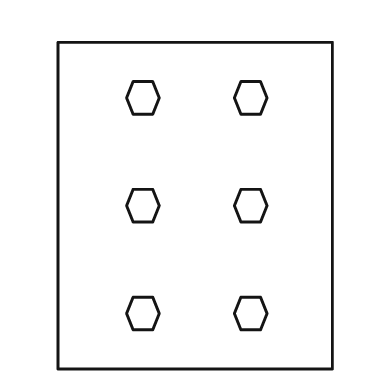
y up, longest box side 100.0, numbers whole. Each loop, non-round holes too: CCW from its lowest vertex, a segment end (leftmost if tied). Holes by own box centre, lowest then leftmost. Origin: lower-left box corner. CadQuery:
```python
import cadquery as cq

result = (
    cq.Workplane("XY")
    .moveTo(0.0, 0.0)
    .lineTo(84.0, 0.0)
    .lineTo(84.0, 100.0)
    .lineTo(0.0, 100.0)
    .close()
    .moveTo(23.0, 12.0)
    .lineTo(29.0, 12.0)
    .lineTo(31.0, 17.0)
    .lineTo(29.0, 22.0)
    .lineTo(23.0, 22.0)
    .lineTo(21.0, 17.0)
    .close()
    .moveTo(56.0, 12.0)
    .lineTo(62.0, 12.0)
    .lineTo(64.0, 17.0)
    .lineTo(62.0, 22.0)
    .lineTo(56.0, 22.0)
    .lineTo(54.0, 17.0)
    .close()
    .moveTo(23.0, 45.0)
    .lineTo(29.0, 45.0)
    .lineTo(31.0, 50.0)
    .lineTo(29.0, 55.0)
    .lineTo(23.0, 55.0)
    .lineTo(21.0, 50.0)
    .close()
    .moveTo(56.0, 45.0)
    .lineTo(62.0, 45.0)
    .lineTo(64.0, 50.0)
    .lineTo(62.0, 55.0)
    .lineTo(56.0, 55.0)
    .lineTo(54.0, 50.0)
    .close()
    .moveTo(23.0, 78.0)
    .lineTo(29.0, 78.0)
    .lineTo(31.0, 83.0)
    .lineTo(29.0, 88.0)
    .lineTo(23.0, 88.0)
    .lineTo(21.0, 83.0)
    .close()
    .moveTo(56.0, 78.0)
    .lineTo(62.0, 78.0)
    .lineTo(64.0, 83.0)
    .lineTo(62.0, 88.0)
    .lineTo(56.0, 88.0)
    .lineTo(54.0, 83.0)
    .close()
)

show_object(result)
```